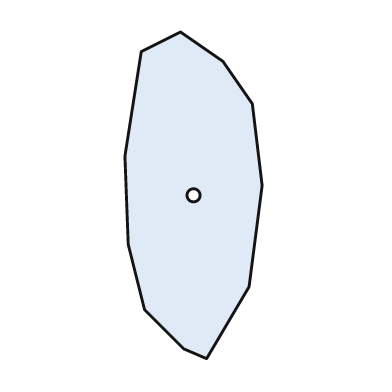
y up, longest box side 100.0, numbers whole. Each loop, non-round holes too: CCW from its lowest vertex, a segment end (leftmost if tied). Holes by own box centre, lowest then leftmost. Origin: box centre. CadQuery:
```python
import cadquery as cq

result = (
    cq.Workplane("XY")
    .moveTo(4.0, -50.0)
    .lineTo(17.0, -28.0)
    .lineTo(21.0, 3.0)
    .lineTo(18.0, 28.0)
    .lineTo(9.0, 41.0)
    .lineTo(-4.0, 50.0)
    .lineTo(-16.0, 44.0)
    .lineTo(-21.0, 12.0)
    .lineTo(-20.0, -15.0)
    .lineTo(-15.0, -35.0)
    .lineTo(-3.0, -47.0)
    .close()
    .moveTo(0.0, 0.0)
    .circle(2.0)
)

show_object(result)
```